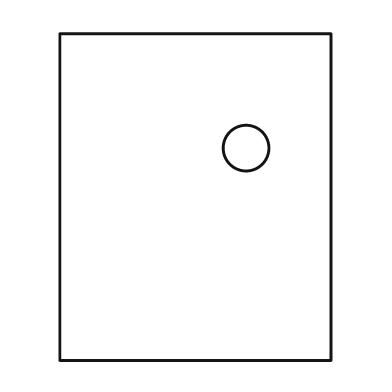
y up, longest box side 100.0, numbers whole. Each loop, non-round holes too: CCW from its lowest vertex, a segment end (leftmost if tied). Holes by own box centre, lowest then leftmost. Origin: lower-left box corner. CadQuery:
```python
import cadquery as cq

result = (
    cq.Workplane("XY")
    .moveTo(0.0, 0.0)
    .lineTo(83.0, 0.0)
    .lineTo(83.0, 100.0)
    .lineTo(0.0, 100.0)
    .close()
    .moveTo(57.0, 65.0)
    .circle(7.0)
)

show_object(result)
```